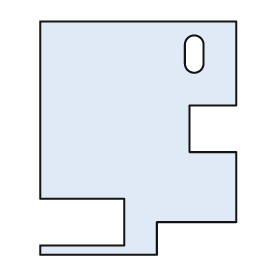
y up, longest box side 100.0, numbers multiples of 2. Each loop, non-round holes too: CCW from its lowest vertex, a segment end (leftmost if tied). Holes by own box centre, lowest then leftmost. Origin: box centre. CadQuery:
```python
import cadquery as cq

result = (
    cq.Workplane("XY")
    .moveTo(-42.0, -50.0)
    .lineTo(8.0, -50.0)
    .lineTo(8.0, -36.0)
    .lineTo(42.0, -36.0)
    .lineTo(42.0, -6.0)
    .lineTo(22.0, -6.0)
    .lineTo(22.0, 14.0)
    .lineTo(42.0, 14.0)
    .lineTo(42.0, 50.0)
    .lineTo(-42.0, 50.0)
    .lineTo(-42.0, -26.0)
    .lineTo(-6.0, -26.0)
    .lineTo(-6.0, -46.0)
    .lineTo(-42.0, -46.0)
    .close()
    .moveTo(20.0, 32.0)
    .threePointArc((24.0, 28.0), (28.0, 32.0))
    .lineTo(28.0, 40.0)
    .threePointArc((24.0, 44.0), (20.0, 40.0))
    .close()
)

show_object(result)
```